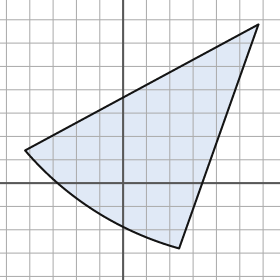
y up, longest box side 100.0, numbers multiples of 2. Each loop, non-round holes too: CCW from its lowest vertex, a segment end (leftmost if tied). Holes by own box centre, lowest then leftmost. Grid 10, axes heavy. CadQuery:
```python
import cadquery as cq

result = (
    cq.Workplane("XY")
    .moveTo(24.0, -28.0)
    .lineTo(58.0, 68.0)
    .lineTo(-42.0, 14.0)
    .threePointArc((-12.0, -12.0), (24.0, -28.0))
    .close()
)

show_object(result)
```